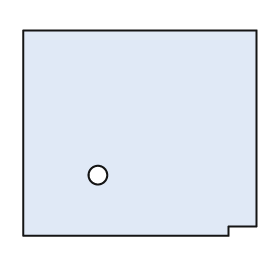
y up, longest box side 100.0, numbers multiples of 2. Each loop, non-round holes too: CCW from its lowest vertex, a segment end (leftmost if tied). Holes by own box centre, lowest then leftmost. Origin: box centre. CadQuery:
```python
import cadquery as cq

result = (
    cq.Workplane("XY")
    .moveTo(-50.0, -44.0)
    .lineTo(38.0, -44.0)
    .lineTo(38.0, -40.0)
    .lineTo(50.0, -40.0)
    .lineTo(50.0, 44.0)
    .lineTo(-50.0, 44.0)
    .close()
    .moveTo(-18.0, -18.0)
    .circle(4.0)
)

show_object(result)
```